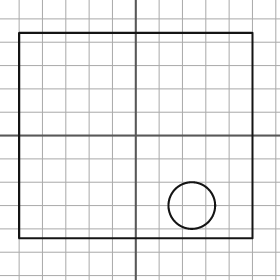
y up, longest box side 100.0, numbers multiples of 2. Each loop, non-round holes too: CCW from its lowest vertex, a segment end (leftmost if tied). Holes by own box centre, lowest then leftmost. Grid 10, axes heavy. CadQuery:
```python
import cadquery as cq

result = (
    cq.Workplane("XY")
    .moveTo(-50.0, -44.0)
    .lineTo(50.0, -44.0)
    .lineTo(50.0, 44.0)
    .lineTo(-50.0, 44.0)
    .close()
    .moveTo(24.0, -30.0)
    .circle(10.0)
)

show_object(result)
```